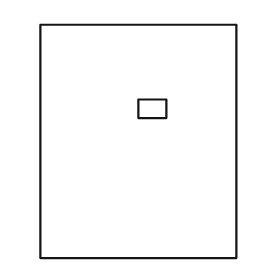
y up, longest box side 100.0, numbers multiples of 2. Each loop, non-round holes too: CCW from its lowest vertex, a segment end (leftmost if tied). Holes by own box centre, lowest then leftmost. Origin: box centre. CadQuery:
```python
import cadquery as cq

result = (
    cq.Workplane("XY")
    .moveTo(-42.0, -50.0)
    .lineTo(42.0, -50.0)
    .lineTo(42.0, 50.0)
    .lineTo(-42.0, 50.0)
    .close()
    .moveTo(0.0, 10.0)
    .lineTo(12.0, 10.0)
    .lineTo(12.0, 18.0)
    .lineTo(0.0, 18.0)
    .close()
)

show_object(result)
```